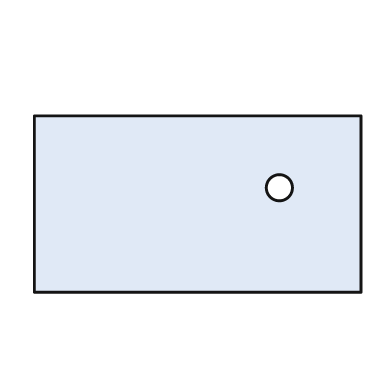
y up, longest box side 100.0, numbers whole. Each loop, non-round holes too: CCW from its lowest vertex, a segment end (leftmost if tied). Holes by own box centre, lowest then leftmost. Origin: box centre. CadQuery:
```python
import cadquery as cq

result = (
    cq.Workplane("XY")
    .moveTo(-50.0, -27.0)
    .lineTo(50.0, -27.0)
    .lineTo(50.0, 27.0)
    .lineTo(-50.0, 27.0)
    .close()
    .moveTo(25.0, 5.0)
    .circle(4.0)
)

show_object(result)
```